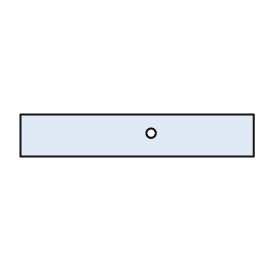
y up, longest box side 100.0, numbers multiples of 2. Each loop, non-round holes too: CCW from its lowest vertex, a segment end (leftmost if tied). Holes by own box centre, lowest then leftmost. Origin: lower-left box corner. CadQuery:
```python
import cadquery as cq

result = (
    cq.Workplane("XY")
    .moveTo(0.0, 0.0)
    .lineTo(100.0, 0.0)
    .lineTo(100.0, 18.0)
    .lineTo(0.0, 18.0)
    .close()
    .moveTo(56.0, 10.0)
    .circle(2.0)
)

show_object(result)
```